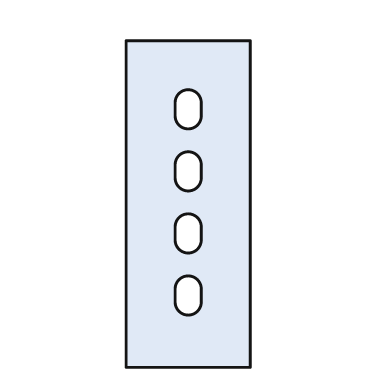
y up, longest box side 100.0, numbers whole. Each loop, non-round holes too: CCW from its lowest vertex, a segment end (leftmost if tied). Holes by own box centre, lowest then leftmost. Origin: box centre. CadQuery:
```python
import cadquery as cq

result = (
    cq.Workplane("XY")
    .moveTo(-19.0, -50.0)
    .lineTo(19.0, -50.0)
    .lineTo(19.0, 50.0)
    .lineTo(-19.0, 50.0)
    .close()
    .moveTo(-4.0, -30.0)
    .threePointArc((0.0, -34.0), (4.0, -30.0))
    .lineTo(4.0, -26.0)
    .threePointArc((0.0, -22.0), (-4.0, -26.0))
    .close()
    .moveTo(-4.0, -11.0)
    .threePointArc((0.0, -15.0), (4.0, -11.0))
    .lineTo(4.0, -7.0)
    .threePointArc((0.0, -3.0), (-4.0, -7.0))
    .close()
    .moveTo(-4.0, 8.0)
    .threePointArc((0.0, 4.0), (4.0, 8.0))
    .lineTo(4.0, 12.0)
    .threePointArc((0.0, 16.0), (-4.0, 12.0))
    .close()
    .moveTo(-4.0, 27.0)
    .threePointArc((0.0, 23.0), (4.0, 27.0))
    .lineTo(4.0, 31.0)
    .threePointArc((0.0, 35.0), (-4.0, 31.0))
    .close()
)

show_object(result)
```